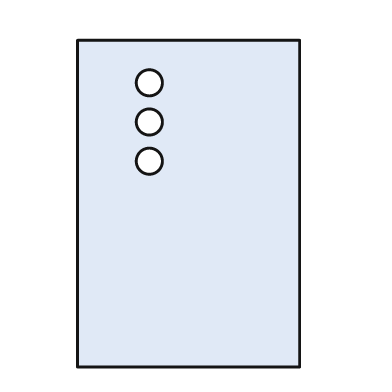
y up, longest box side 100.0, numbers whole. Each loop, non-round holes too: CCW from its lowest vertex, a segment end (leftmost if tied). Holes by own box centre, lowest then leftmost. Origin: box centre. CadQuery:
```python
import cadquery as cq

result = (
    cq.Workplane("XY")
    .moveTo(-34.0, -50.0)
    .lineTo(34.0, -50.0)
    .lineTo(34.0, 50.0)
    .lineTo(-34.0, 50.0)
    .close()
    .moveTo(-12.0, 13.0)
    .circle(4.0)
    .moveTo(-12.0, 25.0)
    .circle(4.0)
    .moveTo(-12.0, 37.0)
    .circle(4.0)
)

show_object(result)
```